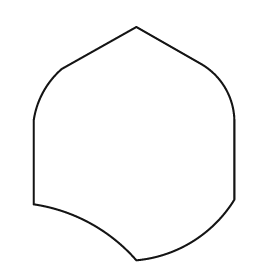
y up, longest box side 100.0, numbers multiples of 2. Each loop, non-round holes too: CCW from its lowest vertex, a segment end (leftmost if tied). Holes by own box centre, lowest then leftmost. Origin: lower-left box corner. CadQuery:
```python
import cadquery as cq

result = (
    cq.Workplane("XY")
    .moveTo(44.0, 0.0)
    .threePointArc((68.0, 8.0), (86.0, 26.0))
    .lineTo(86.0, 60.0)
    .threePointArc((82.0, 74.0), (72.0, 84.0))
    .lineTo(44.0, 100.0)
    .lineTo(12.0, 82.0)
    .threePointArc((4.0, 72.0), (0.0, 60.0))
    .lineTo(0.0, 24.0)
    .threePointArc((24.0, 16.0), (44.0, 0.0))
    .close()
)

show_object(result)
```